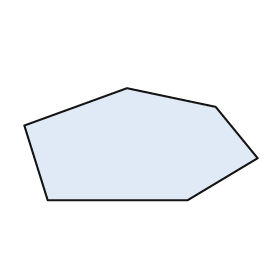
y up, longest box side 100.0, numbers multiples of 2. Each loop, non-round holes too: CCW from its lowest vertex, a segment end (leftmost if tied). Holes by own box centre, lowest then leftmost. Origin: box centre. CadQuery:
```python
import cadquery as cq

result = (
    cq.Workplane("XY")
    .moveTo(-40.0, -24.0)
    .lineTo(20.0, -24.0)
    .lineTo(50.0, -6.0)
    .lineTo(32.0, 16.0)
    .lineTo(-6.0, 24.0)
    .lineTo(-50.0, 8.0)
    .close()
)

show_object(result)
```